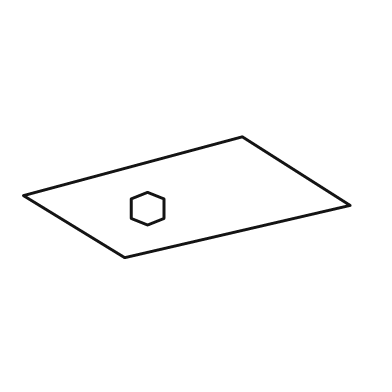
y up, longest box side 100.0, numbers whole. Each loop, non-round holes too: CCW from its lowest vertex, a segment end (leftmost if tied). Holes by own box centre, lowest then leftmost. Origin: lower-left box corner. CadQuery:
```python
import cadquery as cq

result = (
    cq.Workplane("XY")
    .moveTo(31.0, 0.0)
    .lineTo(100.0, 16.0)
    .lineTo(67.0, 37.0)
    .lineTo(0.0, 19.0)
    .close()
    .moveTo(38.0, 10.0)
    .lineTo(43.0, 12.0)
    .lineTo(43.0, 18.0)
    .lineTo(38.0, 20.0)
    .lineTo(33.0, 18.0)
    .lineTo(33.0, 12.0)
    .close()
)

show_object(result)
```